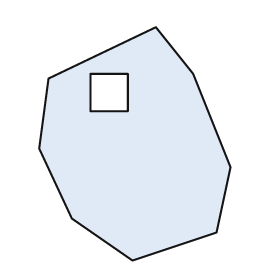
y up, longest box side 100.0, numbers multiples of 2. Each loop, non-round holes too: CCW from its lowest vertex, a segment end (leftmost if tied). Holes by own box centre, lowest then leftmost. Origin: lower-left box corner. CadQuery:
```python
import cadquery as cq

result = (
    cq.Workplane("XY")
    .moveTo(40.0, 0.0)
    .lineTo(76.0, 12.0)
    .lineTo(82.0, 40.0)
    .lineTo(66.0, 80.0)
    .lineTo(50.0, 100.0)
    .lineTo(4.0, 78.0)
    .lineTo(0.0, 48.0)
    .lineTo(14.0, 18.0)
    .close()
    .moveTo(22.0, 64.0)
    .lineTo(38.0, 64.0)
    .lineTo(38.0, 80.0)
    .lineTo(22.0, 80.0)
    .close()
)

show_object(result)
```